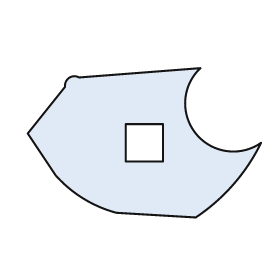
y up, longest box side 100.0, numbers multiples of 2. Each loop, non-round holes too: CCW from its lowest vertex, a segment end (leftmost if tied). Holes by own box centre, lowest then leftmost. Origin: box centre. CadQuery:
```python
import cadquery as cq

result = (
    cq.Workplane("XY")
    .moveTo(22.0, -32.0)
    .threePointArc((38.0, -18.0), (50.0, 0.0))
    .threePointArc((22.0, 4.0), (24.0, 32.0))
    .lineTo(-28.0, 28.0)
    .threePointArc((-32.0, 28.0), (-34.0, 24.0))
    .lineTo(-50.0, 4.0)
    .lineTo(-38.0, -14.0)
    .threePointArc((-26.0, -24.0), (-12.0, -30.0))
    .close()
    .moveTo(-8.0, -8.0)
    .lineTo(8.0, -8.0)
    .lineTo(8.0, 8.0)
    .lineTo(-8.0, 8.0)
    .close()
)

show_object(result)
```